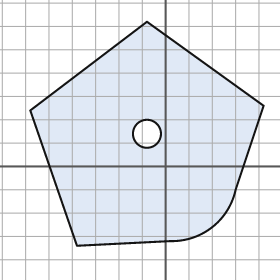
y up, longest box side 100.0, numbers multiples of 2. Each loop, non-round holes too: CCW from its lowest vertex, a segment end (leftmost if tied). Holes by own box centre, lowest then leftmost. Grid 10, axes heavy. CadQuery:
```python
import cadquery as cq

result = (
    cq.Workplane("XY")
    .moveTo(-38.0, -34.0)
    .lineTo(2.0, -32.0)
    .threePointArc((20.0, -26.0), (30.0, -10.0))
    .lineTo(42.0, 26.0)
    .lineTo(-8.0, 62.0)
    .lineTo(-58.0, 24.0)
    .close()
    .moveTo(-8.0, 14.0)
    .circle(6.0)
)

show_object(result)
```